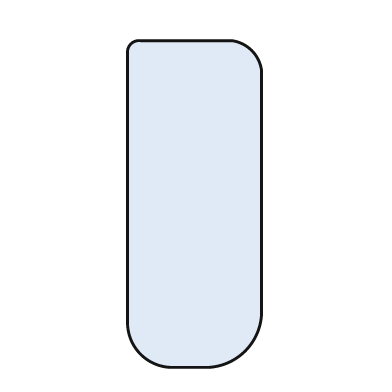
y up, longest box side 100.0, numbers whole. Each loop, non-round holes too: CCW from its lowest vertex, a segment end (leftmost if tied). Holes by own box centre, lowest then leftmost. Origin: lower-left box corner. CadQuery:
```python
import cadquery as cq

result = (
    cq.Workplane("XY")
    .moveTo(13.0, 0.0)
    .lineTo(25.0, 0.0)
    .threePointArc((36.0, 5.0), (41.0, 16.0))
    .lineTo(41.0, 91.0)
    .threePointArc((38.0, 97.0), (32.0, 100.0))
    .lineTo(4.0, 100.0)
    .threePointArc((1.0, 99.0), (0.0, 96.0))
    .lineTo(0.0, 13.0)
    .threePointArc((4.0, 4.0), (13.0, 0.0))
    .close()
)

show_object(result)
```